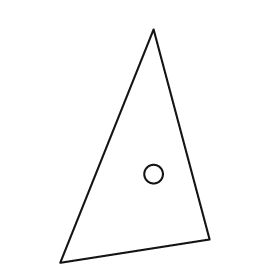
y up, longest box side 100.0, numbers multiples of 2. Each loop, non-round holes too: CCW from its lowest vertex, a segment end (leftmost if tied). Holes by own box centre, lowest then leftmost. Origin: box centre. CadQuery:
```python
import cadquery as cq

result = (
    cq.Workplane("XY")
    .moveTo(-32.0, -50.0)
    .lineTo(32.0, -40.0)
    .lineTo(8.0, 50.0)
    .close()
    .moveTo(8.0, -12.0)
    .circle(4.0)
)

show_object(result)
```